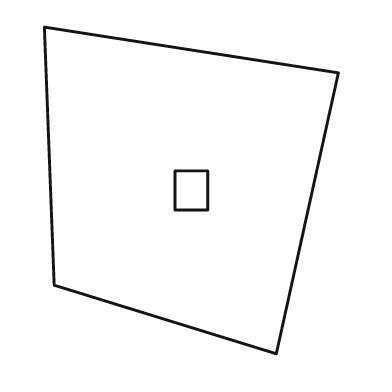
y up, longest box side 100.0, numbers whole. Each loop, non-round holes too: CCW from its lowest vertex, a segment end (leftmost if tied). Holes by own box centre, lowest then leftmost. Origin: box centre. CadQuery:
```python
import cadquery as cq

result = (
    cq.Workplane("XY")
    .moveTo(26.0, -50.0)
    .lineTo(45.0, 36.0)
    .lineTo(-45.0, 50.0)
    .lineTo(-42.0, -29.0)
    .close()
    .moveTo(-5.0, -6.0)
    .lineTo(5.0, -6.0)
    .lineTo(5.0, 6.0)
    .lineTo(-5.0, 6.0)
    .close()
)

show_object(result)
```